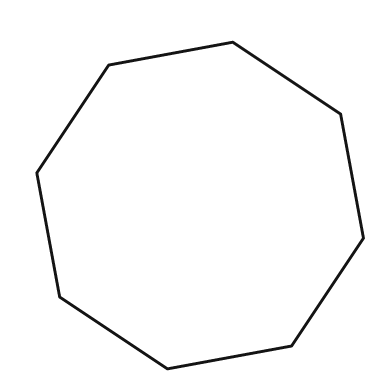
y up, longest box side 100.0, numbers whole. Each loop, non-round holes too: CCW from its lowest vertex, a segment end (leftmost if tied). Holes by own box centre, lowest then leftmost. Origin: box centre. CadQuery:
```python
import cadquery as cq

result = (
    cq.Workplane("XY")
    .moveTo(-10.0, -50.0)
    .lineTo(28.0, -43.0)
    .lineTo(50.0, -10.0)
    .lineTo(43.0, 28.0)
    .lineTo(10.0, 50.0)
    .lineTo(-28.0, 43.0)
    .lineTo(-50.0, 10.0)
    .lineTo(-43.0, -28.0)
    .close()
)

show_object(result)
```